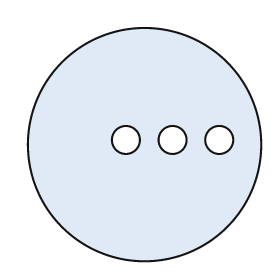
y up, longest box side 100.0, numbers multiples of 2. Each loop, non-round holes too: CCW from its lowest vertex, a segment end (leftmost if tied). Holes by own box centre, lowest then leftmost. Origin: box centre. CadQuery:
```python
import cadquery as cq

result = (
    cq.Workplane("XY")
    .moveTo(0.0, 0.0)
    .circle(50.0)
    .moveTo(-8.0, 2.0)
    .circle(6.0)
    .moveTo(12.0, 2.0)
    .circle(6.0)
    .moveTo(32.0, 2.0)
    .circle(6.0)
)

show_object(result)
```